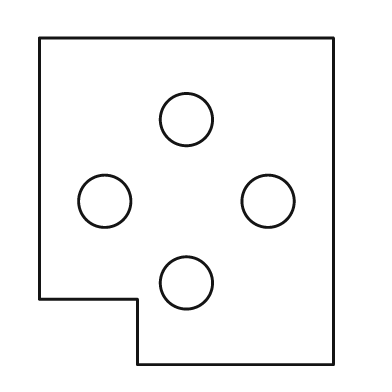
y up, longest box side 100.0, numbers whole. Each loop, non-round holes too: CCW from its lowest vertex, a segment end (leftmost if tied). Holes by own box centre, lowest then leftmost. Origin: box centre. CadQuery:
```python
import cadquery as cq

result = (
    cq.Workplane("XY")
    .moveTo(-15.0, -50.0)
    .lineTo(45.0, -50.0)
    .lineTo(45.0, 50.0)
    .lineTo(-45.0, 50.0)
    .lineTo(-45.0, -30.0)
    .lineTo(-15.0, -30.0)
    .close()
    .moveTo(0.0, -25.0)
    .circle(8.0)
    .moveTo(-25.0, 0.0)
    .circle(8.0)
    .moveTo(25.0, 0.0)
    .circle(8.0)
    .moveTo(0.0, 25.0)
    .circle(8.0)
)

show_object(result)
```